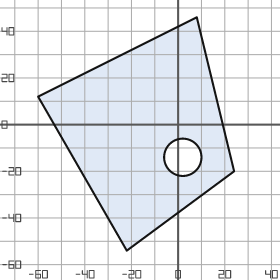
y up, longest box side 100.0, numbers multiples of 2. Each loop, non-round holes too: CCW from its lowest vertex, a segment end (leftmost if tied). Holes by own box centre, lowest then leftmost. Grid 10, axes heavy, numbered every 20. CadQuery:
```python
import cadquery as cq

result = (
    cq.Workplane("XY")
    .moveTo(-22.0, -54.0)
    .lineTo(24.0, -20.0)
    .lineTo(8.0, 46.0)
    .lineTo(-60.0, 12.0)
    .close()
    .moveTo(2.0, -14.0)
    .circle(8.0)
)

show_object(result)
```